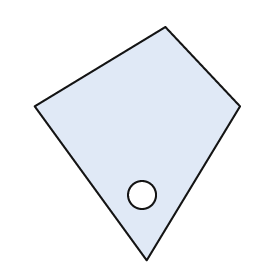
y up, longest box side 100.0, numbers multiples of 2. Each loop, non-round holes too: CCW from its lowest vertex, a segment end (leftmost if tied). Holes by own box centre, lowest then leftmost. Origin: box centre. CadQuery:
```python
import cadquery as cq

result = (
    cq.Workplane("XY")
    .moveTo(4.0, -50.0)
    .lineTo(44.0, 16.0)
    .lineTo(12.0, 50.0)
    .lineTo(-44.0, 16.0)
    .close()
    .moveTo(2.0, -22.0)
    .circle(6.0)
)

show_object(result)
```